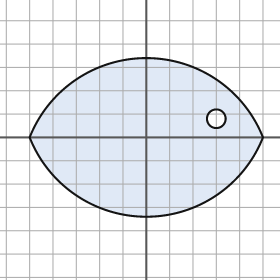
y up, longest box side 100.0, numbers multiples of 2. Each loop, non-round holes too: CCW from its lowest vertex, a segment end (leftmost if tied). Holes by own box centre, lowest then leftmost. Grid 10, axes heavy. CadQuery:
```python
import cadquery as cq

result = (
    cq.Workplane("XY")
    .moveTo(-50.0, 0.0)
    .threePointArc((0.0, -34.0), (50.0, 0.0))
    .threePointArc((0.0, 34.0), (-50.0, 0.0))
    .close()
    .moveTo(30.0, 8.0)
    .circle(4.0)
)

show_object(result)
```